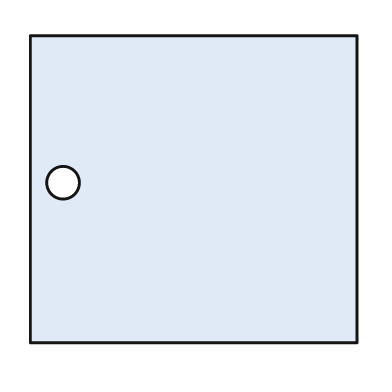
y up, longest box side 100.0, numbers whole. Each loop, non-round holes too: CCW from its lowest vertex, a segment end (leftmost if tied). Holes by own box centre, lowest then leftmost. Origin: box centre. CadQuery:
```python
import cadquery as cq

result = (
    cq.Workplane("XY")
    .moveTo(-50.0, -47.0)
    .lineTo(50.0, -47.0)
    .lineTo(50.0, 47.0)
    .lineTo(-50.0, 47.0)
    .close()
    .moveTo(-40.0, 2.0)
    .circle(5.0)
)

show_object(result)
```